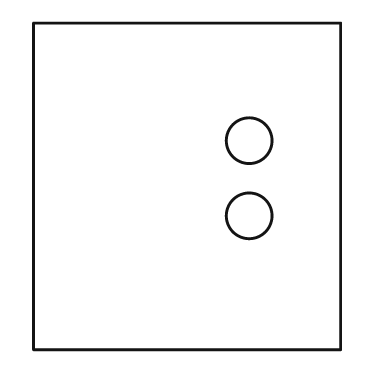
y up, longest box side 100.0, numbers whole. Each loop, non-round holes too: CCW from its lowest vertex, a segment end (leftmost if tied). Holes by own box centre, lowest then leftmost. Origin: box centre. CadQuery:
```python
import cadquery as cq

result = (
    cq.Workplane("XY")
    .moveTo(-47.0, -50.0)
    .lineTo(47.0, -50.0)
    .lineTo(47.0, 50.0)
    .lineTo(-47.0, 50.0)
    .close()
    .moveTo(19.0, -9.0)
    .circle(7.0)
    .moveTo(19.0, 14.0)
    .circle(7.0)
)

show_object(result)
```